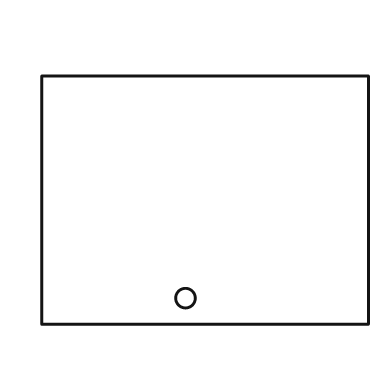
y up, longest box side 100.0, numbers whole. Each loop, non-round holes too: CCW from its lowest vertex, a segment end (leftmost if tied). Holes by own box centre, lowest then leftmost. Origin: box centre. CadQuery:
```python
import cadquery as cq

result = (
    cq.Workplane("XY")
    .moveTo(-50.0, -38.0)
    .lineTo(50.0, -38.0)
    .lineTo(50.0, 38.0)
    .lineTo(-50.0, 38.0)
    .close()
    .moveTo(-6.0, -30.0)
    .circle(3.0)
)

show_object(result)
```